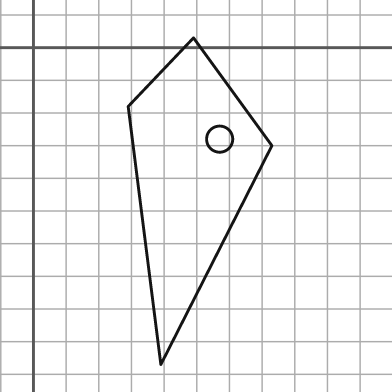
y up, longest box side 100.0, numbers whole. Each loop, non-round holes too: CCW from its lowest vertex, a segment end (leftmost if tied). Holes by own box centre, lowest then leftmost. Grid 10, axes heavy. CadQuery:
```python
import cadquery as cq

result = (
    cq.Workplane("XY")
    .moveTo(39.0, -97.0)
    .lineTo(73.0, -30.0)
    .lineTo(49.0, 3.0)
    .lineTo(29.0, -18.0)
    .close()
    .moveTo(57.0, -28.0)
    .circle(4.0)
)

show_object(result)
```